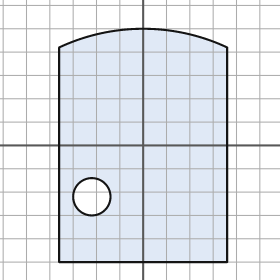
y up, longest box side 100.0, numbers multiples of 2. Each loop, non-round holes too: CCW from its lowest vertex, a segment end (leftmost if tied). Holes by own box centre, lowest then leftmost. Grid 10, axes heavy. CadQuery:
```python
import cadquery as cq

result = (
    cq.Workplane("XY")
    .moveTo(-36.0, -50.0)
    .lineTo(36.0, -50.0)
    .lineTo(36.0, 42.0)
    .threePointArc((0.0, 50.0), (-36.0, 42.0))
    .close()
    .moveTo(-22.0, -22.0)
    .circle(8.0)
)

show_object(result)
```